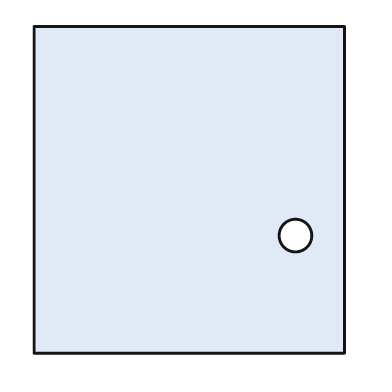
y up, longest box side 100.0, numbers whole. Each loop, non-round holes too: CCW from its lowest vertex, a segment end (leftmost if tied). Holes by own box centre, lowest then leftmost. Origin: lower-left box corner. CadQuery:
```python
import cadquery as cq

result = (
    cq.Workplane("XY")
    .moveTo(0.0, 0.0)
    .lineTo(95.0, 0.0)
    .lineTo(95.0, 100.0)
    .lineTo(0.0, 100.0)
    .close()
    .moveTo(80.0, 36.0)
    .circle(5.0)
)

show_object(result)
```